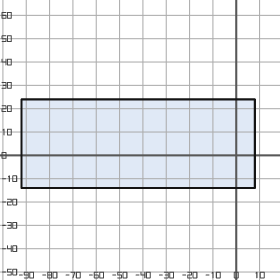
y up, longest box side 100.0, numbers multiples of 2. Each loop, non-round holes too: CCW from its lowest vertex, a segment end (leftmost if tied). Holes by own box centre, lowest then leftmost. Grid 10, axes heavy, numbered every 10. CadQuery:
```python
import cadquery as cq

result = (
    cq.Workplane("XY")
    .moveTo(-92.0, -14.0)
    .lineTo(8.0, -14.0)
    .lineTo(8.0, 24.0)
    .lineTo(-92.0, 24.0)
    .close()
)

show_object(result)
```